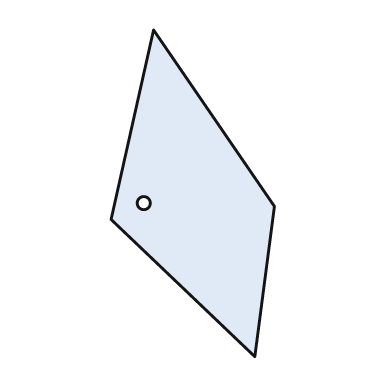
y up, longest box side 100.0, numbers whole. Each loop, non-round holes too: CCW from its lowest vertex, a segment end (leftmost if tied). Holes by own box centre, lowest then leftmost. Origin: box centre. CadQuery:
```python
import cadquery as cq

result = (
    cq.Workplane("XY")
    .moveTo(19.0, -50.0)
    .lineTo(25.0, -4.0)
    .lineTo(-12.0, 50.0)
    .lineTo(-25.0, -8.0)
    .close()
    .moveTo(-15.0, -3.0)
    .circle(2.0)
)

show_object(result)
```